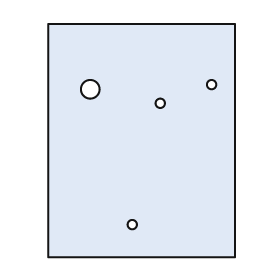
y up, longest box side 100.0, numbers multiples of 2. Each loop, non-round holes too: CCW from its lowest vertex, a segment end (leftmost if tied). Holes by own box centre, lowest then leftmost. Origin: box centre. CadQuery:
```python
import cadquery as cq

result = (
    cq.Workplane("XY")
    .moveTo(-40.0, -50.0)
    .lineTo(40.0, -50.0)
    .lineTo(40.0, 50.0)
    .lineTo(-40.0, 50.0)
    .close()
    .moveTo(-4.0, -36.0)
    .circle(2.0)
    .moveTo(8.0, 16.0)
    .circle(2.0)
    .moveTo(-22.0, 22.0)
    .circle(4.0)
    .moveTo(30.0, 24.0)
    .circle(2.0)
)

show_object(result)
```